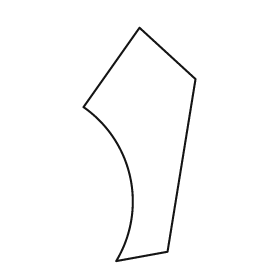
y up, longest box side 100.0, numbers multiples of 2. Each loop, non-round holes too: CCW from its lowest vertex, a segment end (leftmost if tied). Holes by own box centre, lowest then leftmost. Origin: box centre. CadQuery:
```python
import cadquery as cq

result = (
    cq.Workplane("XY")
    .moveTo(-10.0, -50.0)
    .lineTo(12.0, -46.0)
    .lineTo(24.0, 28.0)
    .lineTo(0.0, 50.0)
    .lineTo(-24.0, 16.0)
    .threePointArc((-4.0, -14.0), (-10.0, -50.0))
    .close()
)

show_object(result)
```